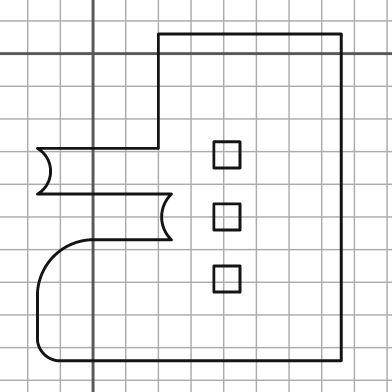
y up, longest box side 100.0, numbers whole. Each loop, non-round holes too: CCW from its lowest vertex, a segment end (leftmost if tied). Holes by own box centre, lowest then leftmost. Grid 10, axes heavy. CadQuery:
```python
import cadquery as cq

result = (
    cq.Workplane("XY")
    .moveTo(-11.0, -94.0)
    .lineTo(76.0, -94.0)
    .lineTo(76.0, 6.0)
    .lineTo(20.0, 6.0)
    .lineTo(20.0, -29.0)
    .lineTo(-17.0, -29.0)
    .threePointArc((-13.0, -36.0), (-17.0, -43.0))
    .lineTo(24.0, -43.0)
    .threePointArc((21.0, -50.0), (24.0, -57.0))
    .lineTo(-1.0, -57.0)
    .threePointArc((-12.0, -62.0), (-17.0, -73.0))
    .lineTo(-17.0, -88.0)
    .threePointArc((-15.0, -92.0), (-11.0, -94.0))
    .close()
    .moveTo(37.0, -73.0)
    .lineTo(45.0, -73.0)
    .lineTo(45.0, -65.0)
    .lineTo(37.0, -65.0)
    .close()
    .moveTo(37.0, -54.0)
    .lineTo(45.0, -54.0)
    .lineTo(45.0, -46.0)
    .lineTo(37.0, -46.0)
    .close()
    .moveTo(37.0, -35.0)
    .lineTo(45.0, -35.0)
    .lineTo(45.0, -27.0)
    .lineTo(37.0, -27.0)
    .close()
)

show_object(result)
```